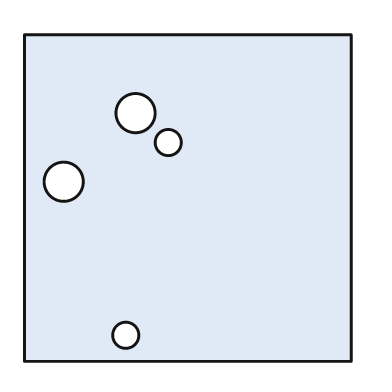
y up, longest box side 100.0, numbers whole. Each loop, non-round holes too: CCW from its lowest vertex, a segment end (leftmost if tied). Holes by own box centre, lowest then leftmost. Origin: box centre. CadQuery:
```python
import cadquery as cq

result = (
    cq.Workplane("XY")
    .moveTo(-50.0, -50.0)
    .lineTo(50.0, -50.0)
    .lineTo(50.0, 50.0)
    .lineTo(-50.0, 50.0)
    .close()
    .moveTo(-19.0, -42.0)
    .circle(4.0)
    .moveTo(-38.0, 5.0)
    .circle(6.0)
    .moveTo(-6.0, 17.0)
    .circle(4.0)
    .moveTo(-16.0, 26.0)
    .circle(6.0)
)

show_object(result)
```